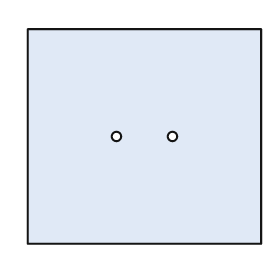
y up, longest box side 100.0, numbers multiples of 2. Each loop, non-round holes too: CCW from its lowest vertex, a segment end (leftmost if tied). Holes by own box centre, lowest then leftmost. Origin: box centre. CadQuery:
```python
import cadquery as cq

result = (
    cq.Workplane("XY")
    .moveTo(-50.0, -46.0)
    .lineTo(50.0, -46.0)
    .lineTo(50.0, 46.0)
    .lineTo(-50.0, 46.0)
    .close()
    .moveTo(-12.0, 0.0)
    .circle(2.0)
    .moveTo(12.0, 0.0)
    .circle(2.0)
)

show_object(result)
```